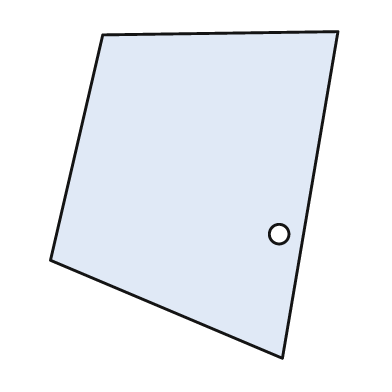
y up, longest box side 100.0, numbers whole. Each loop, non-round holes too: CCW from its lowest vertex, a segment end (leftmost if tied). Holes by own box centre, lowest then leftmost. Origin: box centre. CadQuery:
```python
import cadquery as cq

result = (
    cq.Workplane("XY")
    .moveTo(27.0, -50.0)
    .lineTo(44.0, 50.0)
    .lineTo(-28.0, 49.0)
    .lineTo(-44.0, -20.0)
    .close()
    .moveTo(26.0, -12.0)
    .circle(3.0)
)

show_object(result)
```